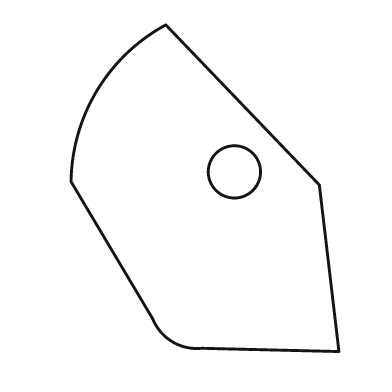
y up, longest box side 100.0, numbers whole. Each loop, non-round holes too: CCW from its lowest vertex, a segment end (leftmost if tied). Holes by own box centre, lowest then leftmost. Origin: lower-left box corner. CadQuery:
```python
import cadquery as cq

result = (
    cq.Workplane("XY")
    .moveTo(82.0, 0.0)
    .lineTo(76.0, 51.0)
    .lineTo(29.0, 100.0)
    .threePointArc((8.0, 80.0), (0.0, 52.0))
    .lineTo(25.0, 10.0)
    .threePointArc((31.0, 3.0), (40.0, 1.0))
    .close()
    .moveTo(50.0, 55.0)
    .circle(8.0)
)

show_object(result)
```